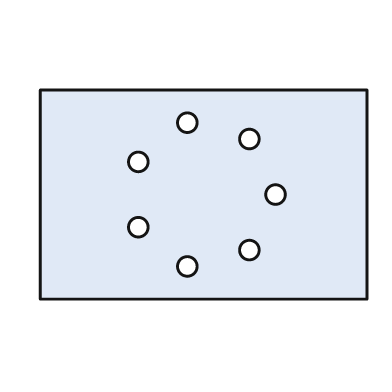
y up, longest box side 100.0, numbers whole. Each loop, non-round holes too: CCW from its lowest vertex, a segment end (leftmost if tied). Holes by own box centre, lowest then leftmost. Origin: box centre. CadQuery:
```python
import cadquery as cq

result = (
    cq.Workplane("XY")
    .moveTo(-50.0, -32.0)
    .lineTo(50.0, -32.0)
    .lineTo(50.0, 32.0)
    .lineTo(-50.0, 32.0)
    .close()
    .moveTo(-5.0, -22.0)
    .circle(3.0)
    .moveTo(14.0, -17.0)
    .circle(3.0)
    .moveTo(-20.0, -10.0)
    .circle(3.0)
    .moveTo(22.0, 0.0)
    .circle(3.0)
    .moveTo(-20.0, 10.0)
    .circle(3.0)
    .moveTo(14.0, 17.0)
    .circle(3.0)
    .moveTo(-5.0, 22.0)
    .circle(3.0)
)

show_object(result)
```